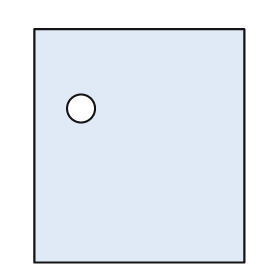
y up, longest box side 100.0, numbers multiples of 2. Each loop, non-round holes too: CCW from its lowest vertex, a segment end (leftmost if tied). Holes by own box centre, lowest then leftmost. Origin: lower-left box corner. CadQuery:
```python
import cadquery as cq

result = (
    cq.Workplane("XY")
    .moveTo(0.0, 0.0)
    .lineTo(90.0, 0.0)
    .lineTo(90.0, 100.0)
    .lineTo(0.0, 100.0)
    .close()
    .moveTo(20.0, 66.0)
    .circle(6.0)
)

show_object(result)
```